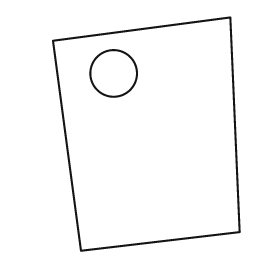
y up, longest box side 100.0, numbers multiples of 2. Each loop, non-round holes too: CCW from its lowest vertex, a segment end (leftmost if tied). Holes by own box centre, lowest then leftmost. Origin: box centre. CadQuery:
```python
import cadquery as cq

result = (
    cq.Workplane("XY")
    .moveTo(-28.0, -50.0)
    .lineTo(40.0, -42.0)
    .lineTo(36.0, 50.0)
    .lineTo(-40.0, 40.0)
    .close()
    .moveTo(-14.0, 26.0)
    .circle(10.0)
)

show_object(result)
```